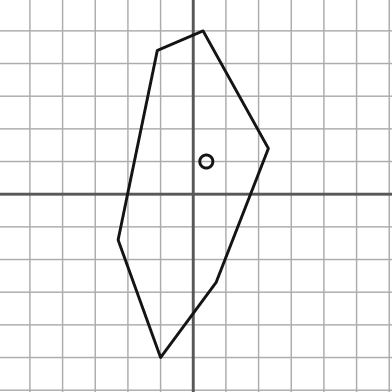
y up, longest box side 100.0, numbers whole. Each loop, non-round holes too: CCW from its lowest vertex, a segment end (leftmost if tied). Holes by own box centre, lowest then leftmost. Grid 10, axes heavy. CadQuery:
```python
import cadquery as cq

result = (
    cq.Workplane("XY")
    .moveTo(-10.0, -50.0)
    .lineTo(7.0, -27.0)
    .lineTo(23.0, 14.0)
    .lineTo(3.0, 50.0)
    .lineTo(-11.0, 44.0)
    .lineTo(-23.0, -14.0)
    .close()
    .moveTo(4.0, 10.0)
    .circle(2.0)
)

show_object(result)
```